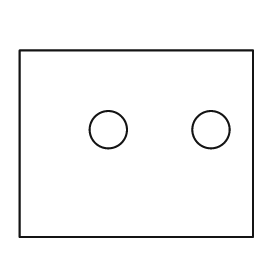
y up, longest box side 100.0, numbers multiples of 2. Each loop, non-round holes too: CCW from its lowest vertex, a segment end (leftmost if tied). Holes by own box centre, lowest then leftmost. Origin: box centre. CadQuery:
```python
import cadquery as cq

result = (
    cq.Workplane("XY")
    .moveTo(-50.0, -40.0)
    .lineTo(50.0, -40.0)
    .lineTo(50.0, 40.0)
    .lineTo(-50.0, 40.0)
    .close()
    .moveTo(-12.0, 6.0)
    .circle(8.0)
    .moveTo(32.0, 6.0)
    .circle(8.0)
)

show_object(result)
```